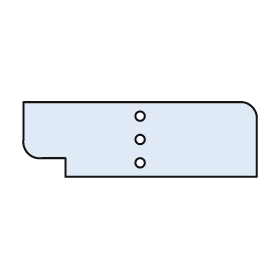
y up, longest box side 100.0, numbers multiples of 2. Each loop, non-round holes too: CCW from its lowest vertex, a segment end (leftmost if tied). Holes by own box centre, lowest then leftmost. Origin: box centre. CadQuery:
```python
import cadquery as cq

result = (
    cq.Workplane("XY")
    .moveTo(-32.0, -16.0)
    .lineTo(50.0, -16.0)
    .lineTo(50.0, 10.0)
    .threePointArc((48.0, 14.0), (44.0, 16.0))
    .lineTo(-50.0, 16.0)
    .lineTo(-50.0, 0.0)
    .threePointArc((-48.0, -6.0), (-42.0, -8.0))
    .lineTo(-32.0, -8.0)
    .close()
    .moveTo(0.0, -10.0)
    .circle(2.0)
    .moveTo(0.0, 0.0)
    .circle(2.0)
    .moveTo(0.0, 10.0)
    .circle(2.0)
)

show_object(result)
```